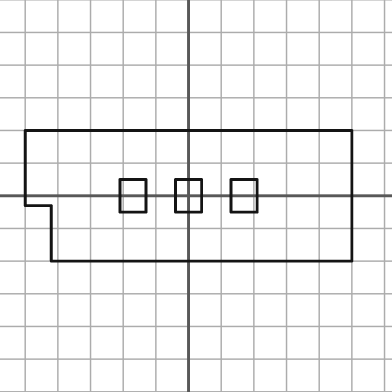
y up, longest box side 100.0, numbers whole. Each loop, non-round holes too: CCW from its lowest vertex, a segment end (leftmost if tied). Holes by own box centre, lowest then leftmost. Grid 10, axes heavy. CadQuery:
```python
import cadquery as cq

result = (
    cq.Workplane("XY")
    .moveTo(-42.0, -20.0)
    .lineTo(50.0, -20.0)
    .lineTo(50.0, 20.0)
    .lineTo(-50.0, 20.0)
    .lineTo(-50.0, -3.0)
    .lineTo(-42.0, -3.0)
    .close()
    .moveTo(-21.0, -5.0)
    .lineTo(-13.0, -5.0)
    .lineTo(-13.0, 5.0)
    .lineTo(-21.0, 5.0)
    .close()
    .moveTo(-4.0, -5.0)
    .lineTo(4.0, -5.0)
    .lineTo(4.0, 5.0)
    .lineTo(-4.0, 5.0)
    .close()
    .moveTo(13.0, -5.0)
    .lineTo(21.0, -5.0)
    .lineTo(21.0, 5.0)
    .lineTo(13.0, 5.0)
    .close()
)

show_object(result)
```